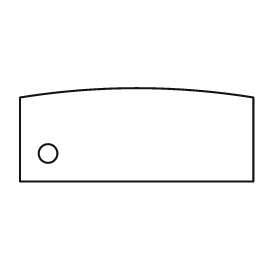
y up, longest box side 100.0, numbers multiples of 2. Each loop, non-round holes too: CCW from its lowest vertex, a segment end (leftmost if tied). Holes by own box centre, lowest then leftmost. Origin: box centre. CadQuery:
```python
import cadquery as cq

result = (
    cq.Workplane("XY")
    .moveTo(-50.0, -20.0)
    .lineTo(50.0, -20.0)
    .lineTo(50.0, 16.0)
    .threePointArc((0.0, 20.0), (-50.0, 16.0))
    .close()
    .moveTo(-38.0, -8.0)
    .circle(4.0)
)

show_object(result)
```